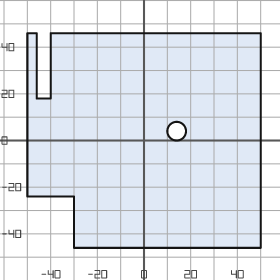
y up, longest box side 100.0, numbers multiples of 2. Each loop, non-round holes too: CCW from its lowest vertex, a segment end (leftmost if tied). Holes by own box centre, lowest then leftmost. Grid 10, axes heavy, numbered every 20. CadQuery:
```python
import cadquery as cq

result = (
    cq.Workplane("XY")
    .moveTo(-30.0, -46.0)
    .lineTo(50.0, -46.0)
    .lineTo(50.0, 46.0)
    .lineTo(-40.0, 46.0)
    .lineTo(-40.0, 18.0)
    .lineTo(-46.0, 18.0)
    .lineTo(-46.0, 46.0)
    .lineTo(-50.0, 46.0)
    .lineTo(-50.0, -24.0)
    .lineTo(-30.0, -24.0)
    .close()
    .moveTo(14.0, 4.0)
    .circle(4.0)
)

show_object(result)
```